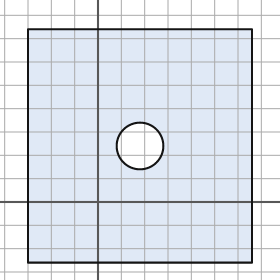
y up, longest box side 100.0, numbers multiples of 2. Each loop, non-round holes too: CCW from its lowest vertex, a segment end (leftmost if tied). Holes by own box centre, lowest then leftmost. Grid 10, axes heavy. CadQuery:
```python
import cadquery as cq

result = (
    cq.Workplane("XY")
    .moveTo(-30.0, -26.0)
    .lineTo(66.0, -26.0)
    .lineTo(66.0, 74.0)
    .lineTo(-30.0, 74.0)
    .close()
    .moveTo(18.0, 24.0)
    .circle(10.0)
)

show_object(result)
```